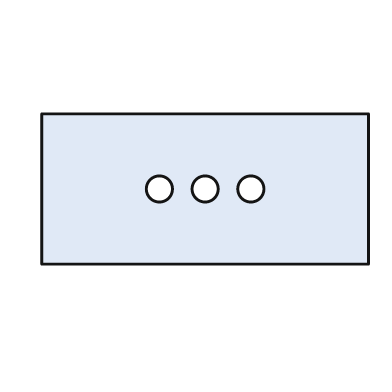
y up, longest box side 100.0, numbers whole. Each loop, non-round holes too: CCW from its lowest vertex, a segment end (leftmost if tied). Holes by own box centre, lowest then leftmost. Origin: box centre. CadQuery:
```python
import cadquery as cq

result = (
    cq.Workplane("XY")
    .moveTo(-50.0, -23.0)
    .lineTo(50.0, -23.0)
    .lineTo(50.0, 23.0)
    .lineTo(-50.0, 23.0)
    .close()
    .moveTo(-14.0, 0.0)
    .circle(4.0)
    .moveTo(0.0, 0.0)
    .circle(4.0)
    .moveTo(14.0, 0.0)
    .circle(4.0)
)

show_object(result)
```